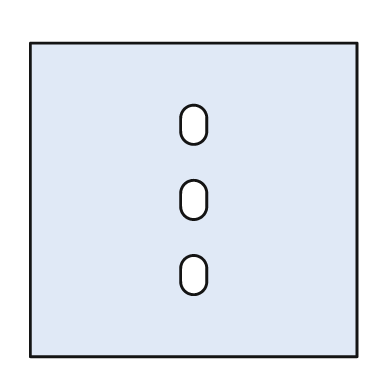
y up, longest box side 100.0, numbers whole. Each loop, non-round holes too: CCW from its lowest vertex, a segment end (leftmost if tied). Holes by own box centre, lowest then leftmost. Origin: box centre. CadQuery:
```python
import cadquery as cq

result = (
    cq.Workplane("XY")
    .moveTo(-50.0, -48.0)
    .lineTo(50.0, -48.0)
    .lineTo(50.0, 48.0)
    .lineTo(-50.0, 48.0)
    .close()
    .moveTo(-4.0, -25.0)
    .threePointArc((0.0, -29.0), (4.0, -25.0))
    .lineTo(4.0, -21.0)
    .threePointArc((0.0, -17.0), (-4.0, -21.0))
    .close()
    .moveTo(-4.0, -2.0)
    .threePointArc((0.0, -6.0), (4.0, -2.0))
    .lineTo(4.0, 2.0)
    .threePointArc((0.0, 6.0), (-4.0, 2.0))
    .close()
    .moveTo(-4.0, 21.0)
    .threePointArc((0.0, 17.0), (4.0, 21.0))
    .lineTo(4.0, 25.0)
    .threePointArc((0.0, 29.0), (-4.0, 25.0))
    .close()
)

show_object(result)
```